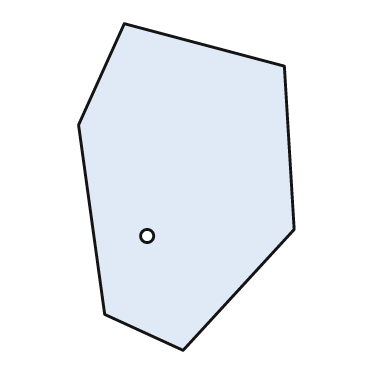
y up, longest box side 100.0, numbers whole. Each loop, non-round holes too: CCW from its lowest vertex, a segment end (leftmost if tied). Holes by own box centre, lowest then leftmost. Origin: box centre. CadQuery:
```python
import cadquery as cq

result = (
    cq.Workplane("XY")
    .moveTo(-1.0, -50.0)
    .lineTo(33.0, -13.0)
    .lineTo(30.0, 37.0)
    .lineTo(-19.0, 50.0)
    .lineTo(-33.0, 19.0)
    .lineTo(-25.0, -39.0)
    .close()
    .moveTo(-12.0, -15.0)
    .circle(2.0)
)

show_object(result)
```